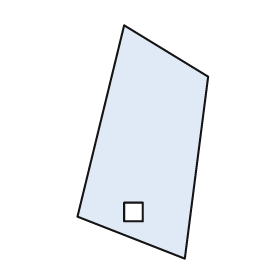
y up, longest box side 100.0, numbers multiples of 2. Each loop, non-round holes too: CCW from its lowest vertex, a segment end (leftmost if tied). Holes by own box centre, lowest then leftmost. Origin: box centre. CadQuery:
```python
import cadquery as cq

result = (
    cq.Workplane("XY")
    .moveTo(18.0, -50.0)
    .lineTo(28.0, 28.0)
    .lineTo(-8.0, 50.0)
    .lineTo(-28.0, -32.0)
    .close()
    .moveTo(-8.0, -34.0)
    .lineTo(0.0, -34.0)
    .lineTo(0.0, -26.0)
    .lineTo(-8.0, -26.0)
    .close()
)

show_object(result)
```